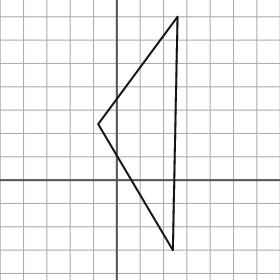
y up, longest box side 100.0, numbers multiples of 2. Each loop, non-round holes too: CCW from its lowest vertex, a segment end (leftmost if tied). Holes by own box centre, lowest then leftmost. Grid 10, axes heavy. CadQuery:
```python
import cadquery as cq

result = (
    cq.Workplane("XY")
    .moveTo(24.0, -30.0)
    .lineTo(26.0, 70.0)
    .lineTo(-8.0, 24.0)
    .close()
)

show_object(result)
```